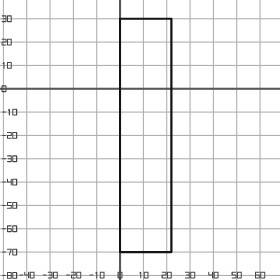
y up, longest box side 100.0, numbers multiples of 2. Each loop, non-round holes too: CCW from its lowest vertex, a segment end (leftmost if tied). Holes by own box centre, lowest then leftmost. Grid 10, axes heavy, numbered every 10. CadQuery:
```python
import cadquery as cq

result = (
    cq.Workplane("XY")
    .moveTo(0.0, -70.0)
    .lineTo(22.0, -70.0)
    .lineTo(22.0, 30.0)
    .lineTo(0.0, 30.0)
    .close()
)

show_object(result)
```